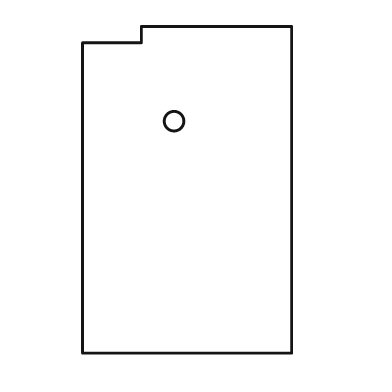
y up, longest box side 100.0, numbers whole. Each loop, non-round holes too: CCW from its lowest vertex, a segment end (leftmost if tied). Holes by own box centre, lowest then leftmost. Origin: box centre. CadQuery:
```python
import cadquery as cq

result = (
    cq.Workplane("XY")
    .moveTo(-32.0, -50.0)
    .lineTo(32.0, -50.0)
    .lineTo(32.0, 50.0)
    .lineTo(-14.0, 50.0)
    .lineTo(-14.0, 45.0)
    .lineTo(-32.0, 45.0)
    .close()
    .moveTo(-4.0, 21.0)
    .circle(3.0)
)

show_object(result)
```